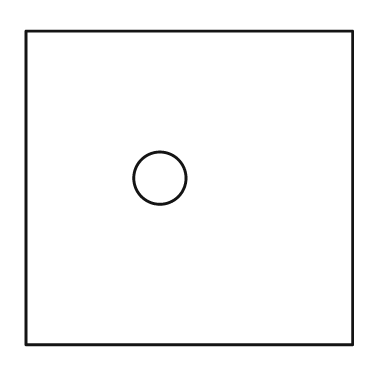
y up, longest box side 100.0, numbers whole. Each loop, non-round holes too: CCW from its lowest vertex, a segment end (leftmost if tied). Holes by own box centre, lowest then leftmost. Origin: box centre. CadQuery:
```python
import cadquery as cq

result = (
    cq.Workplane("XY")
    .moveTo(-50.0, -48.0)
    .lineTo(50.0, -48.0)
    .lineTo(50.0, 48.0)
    .lineTo(-50.0, 48.0)
    .close()
    .moveTo(-9.0, 3.0)
    .circle(8.0)
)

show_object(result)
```